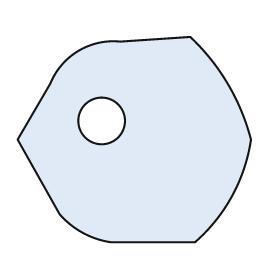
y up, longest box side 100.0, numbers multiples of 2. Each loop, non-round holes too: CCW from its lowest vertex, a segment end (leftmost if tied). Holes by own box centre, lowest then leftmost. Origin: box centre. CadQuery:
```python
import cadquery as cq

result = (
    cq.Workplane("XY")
    .moveTo(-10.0, -44.0)
    .lineTo(26.0, -44.0)
    .threePointArc((42.0, -24.0), (50.0, 0.0))
    .threePointArc((40.0, 24.0), (24.0, 44.0))
    .lineTo(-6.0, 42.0)
    .threePointArc((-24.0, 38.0), (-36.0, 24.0))
    .lineTo(-50.0, 0.0)
    .lineTo(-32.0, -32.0)
    .threePointArc((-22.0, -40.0), (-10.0, -44.0))
    .close()
    .moveTo(-14.0, 8.0)
    .circle(10.0)
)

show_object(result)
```